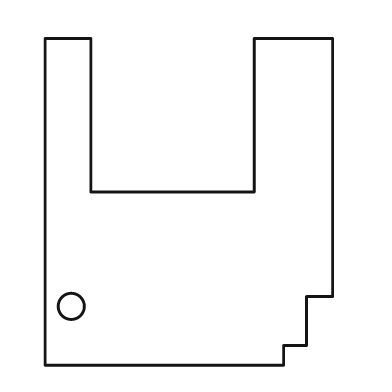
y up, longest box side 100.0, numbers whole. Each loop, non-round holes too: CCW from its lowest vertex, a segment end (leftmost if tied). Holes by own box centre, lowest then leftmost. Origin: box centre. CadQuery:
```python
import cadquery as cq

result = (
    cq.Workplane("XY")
    .moveTo(-44.0, -50.0)
    .lineTo(29.0, -50.0)
    .lineTo(29.0, -44.0)
    .lineTo(36.0, -44.0)
    .lineTo(36.0, -29.0)
    .lineTo(44.0, -29.0)
    .lineTo(44.0, 50.0)
    .lineTo(20.0, 50.0)
    .lineTo(20.0, 3.0)
    .lineTo(-30.0, 3.0)
    .lineTo(-30.0, 50.0)
    .lineTo(-44.0, 50.0)
    .close()
    .moveTo(-36.0, -32.0)
    .circle(4.0)
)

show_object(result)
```